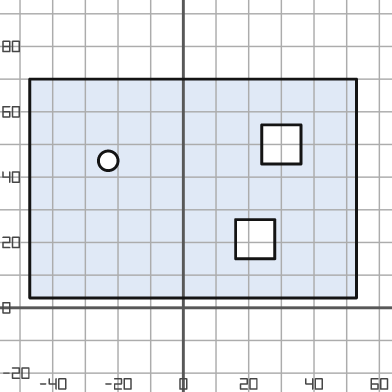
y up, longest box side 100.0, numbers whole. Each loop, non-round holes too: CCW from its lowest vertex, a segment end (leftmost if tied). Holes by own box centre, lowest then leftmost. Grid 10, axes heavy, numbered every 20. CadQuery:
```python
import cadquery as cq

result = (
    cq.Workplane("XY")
    .moveTo(-47.0, 3.0)
    .lineTo(53.0, 3.0)
    .lineTo(53.0, 70.0)
    .lineTo(-47.0, 70.0)
    .close()
    .moveTo(16.0, 15.0)
    .lineTo(28.0, 15.0)
    .lineTo(28.0, 27.0)
    .lineTo(16.0, 27.0)
    .close()
    .moveTo(-23.0, 45.0)
    .circle(3.0)
    .moveTo(24.0, 44.0)
    .lineTo(36.0, 44.0)
    .lineTo(36.0, 56.0)
    .lineTo(24.0, 56.0)
    .close()
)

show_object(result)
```